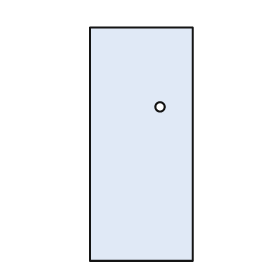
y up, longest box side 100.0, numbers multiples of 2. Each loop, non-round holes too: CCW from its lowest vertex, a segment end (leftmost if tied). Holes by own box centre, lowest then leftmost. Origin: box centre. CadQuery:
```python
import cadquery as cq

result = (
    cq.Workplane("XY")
    .moveTo(-22.0, -50.0)
    .lineTo(22.0, -50.0)
    .lineTo(22.0, 50.0)
    .lineTo(-22.0, 50.0)
    .close()
    .moveTo(8.0, 16.0)
    .circle(2.0)
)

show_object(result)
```